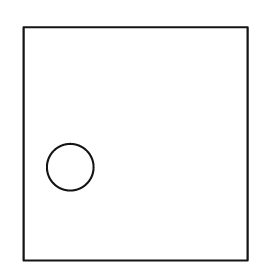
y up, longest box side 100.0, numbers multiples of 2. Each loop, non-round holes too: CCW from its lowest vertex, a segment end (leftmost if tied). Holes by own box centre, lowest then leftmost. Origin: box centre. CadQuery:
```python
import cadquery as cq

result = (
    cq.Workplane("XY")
    .moveTo(-48.0, -50.0)
    .lineTo(48.0, -50.0)
    .lineTo(48.0, 50.0)
    .lineTo(-48.0, 50.0)
    .close()
    .moveTo(-28.0, -10.0)
    .circle(10.0)
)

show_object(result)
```